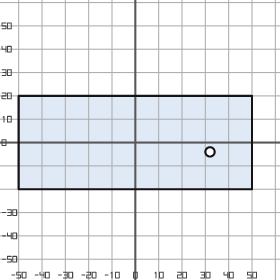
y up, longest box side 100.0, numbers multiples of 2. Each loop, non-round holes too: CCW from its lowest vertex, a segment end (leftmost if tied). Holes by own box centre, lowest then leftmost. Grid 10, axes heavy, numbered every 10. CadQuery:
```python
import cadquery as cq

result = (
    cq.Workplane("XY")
    .moveTo(-50.0, -20.0)
    .lineTo(50.0, -20.0)
    .lineTo(50.0, 20.0)
    .lineTo(-50.0, 20.0)
    .close()
    .moveTo(32.0, -4.0)
    .circle(2.0)
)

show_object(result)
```